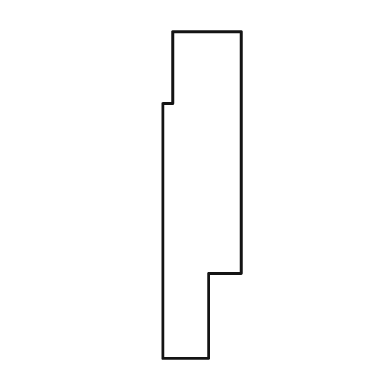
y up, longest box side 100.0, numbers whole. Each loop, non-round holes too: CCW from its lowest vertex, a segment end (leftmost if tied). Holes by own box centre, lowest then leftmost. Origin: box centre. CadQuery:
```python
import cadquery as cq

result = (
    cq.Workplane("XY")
    .moveTo(-12.0, -50.0)
    .lineTo(2.0, -50.0)
    .lineTo(2.0, -24.0)
    .lineTo(12.0, -24.0)
    .lineTo(12.0, 50.0)
    .lineTo(-9.0, 50.0)
    .lineTo(-9.0, 28.0)
    .lineTo(-12.0, 28.0)
    .close()
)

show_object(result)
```